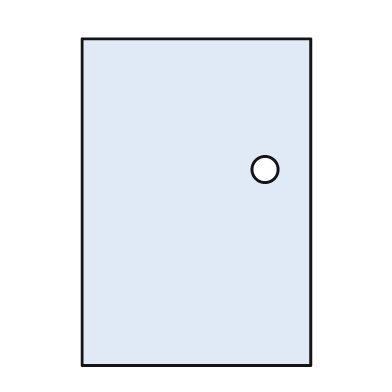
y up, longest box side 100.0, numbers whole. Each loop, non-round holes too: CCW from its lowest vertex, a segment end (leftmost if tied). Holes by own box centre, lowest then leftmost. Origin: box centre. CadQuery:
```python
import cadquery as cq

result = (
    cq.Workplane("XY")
    .moveTo(-35.0, -50.0)
    .lineTo(35.0, -50.0)
    .lineTo(35.0, 50.0)
    .lineTo(-35.0, 50.0)
    .close()
    .moveTo(21.0, 10.0)
    .circle(4.0)
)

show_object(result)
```